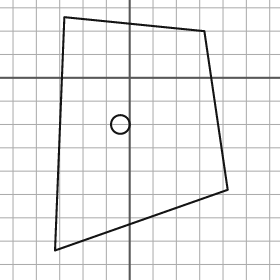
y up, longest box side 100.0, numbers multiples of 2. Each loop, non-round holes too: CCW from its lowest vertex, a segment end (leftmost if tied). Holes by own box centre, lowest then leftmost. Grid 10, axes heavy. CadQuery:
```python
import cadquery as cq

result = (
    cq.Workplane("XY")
    .moveTo(-32.0, -74.0)
    .lineTo(42.0, -48.0)
    .lineTo(32.0, 20.0)
    .lineTo(-28.0, 26.0)
    .close()
    .moveTo(-4.0, -20.0)
    .circle(4.0)
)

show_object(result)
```